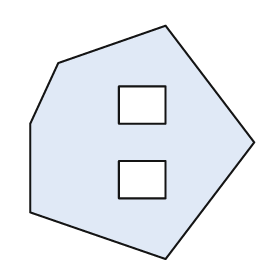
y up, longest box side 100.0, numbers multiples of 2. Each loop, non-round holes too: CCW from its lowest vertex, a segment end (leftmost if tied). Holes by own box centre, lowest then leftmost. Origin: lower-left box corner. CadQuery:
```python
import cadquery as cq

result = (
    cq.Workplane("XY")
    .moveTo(58.0, 0.0)
    .lineTo(96.0, 50.0)
    .lineTo(58.0, 100.0)
    .lineTo(12.0, 84.0)
    .lineTo(0.0, 58.0)
    .lineTo(0.0, 20.0)
    .close()
    .moveTo(38.0, 26.0)
    .lineTo(58.0, 26.0)
    .lineTo(58.0, 42.0)
    .lineTo(38.0, 42.0)
    .close()
    .moveTo(38.0, 58.0)
    .lineTo(58.0, 58.0)
    .lineTo(58.0, 74.0)
    .lineTo(38.0, 74.0)
    .close()
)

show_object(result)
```